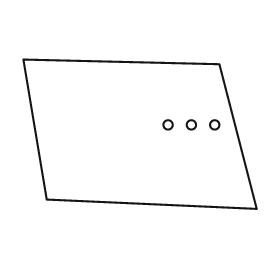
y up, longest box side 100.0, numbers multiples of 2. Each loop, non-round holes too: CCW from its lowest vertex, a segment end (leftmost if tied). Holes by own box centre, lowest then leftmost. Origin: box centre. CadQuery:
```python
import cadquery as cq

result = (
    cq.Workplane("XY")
    .moveTo(50.0, -32.0)
    .lineTo(34.0, 30.0)
    .lineTo(-50.0, 32.0)
    .lineTo(-40.0, -28.0)
    .close()
    .moveTo(12.0, 4.0)
    .circle(2.0)
    .moveTo(22.0, 4.0)
    .circle(2.0)
    .moveTo(32.0, 4.0)
    .circle(2.0)
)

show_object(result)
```